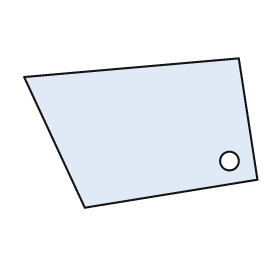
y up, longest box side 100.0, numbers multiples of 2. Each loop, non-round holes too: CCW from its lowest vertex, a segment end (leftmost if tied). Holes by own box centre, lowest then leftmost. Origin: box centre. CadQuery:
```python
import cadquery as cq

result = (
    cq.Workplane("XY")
    .moveTo(-24.0, -32.0)
    .lineTo(50.0, -20.0)
    .lineTo(42.0, 32.0)
    .lineTo(-50.0, 24.0)
    .close()
    .moveTo(38.0, -12.0)
    .circle(4.0)
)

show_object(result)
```